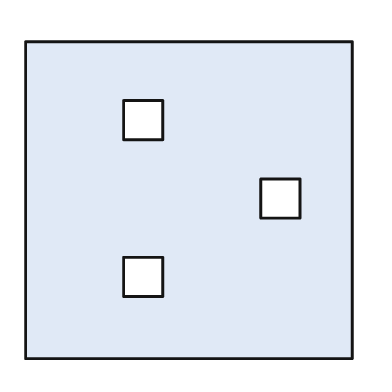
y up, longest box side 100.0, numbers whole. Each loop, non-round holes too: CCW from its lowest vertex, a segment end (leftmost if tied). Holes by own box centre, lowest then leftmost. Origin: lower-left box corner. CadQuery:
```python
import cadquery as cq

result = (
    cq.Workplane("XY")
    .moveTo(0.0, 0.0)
    .lineTo(100.0, 0.0)
    .lineTo(100.0, 97.0)
    .lineTo(0.0, 97.0)
    .close()
    .moveTo(30.0, 19.0)
    .lineTo(42.0, 19.0)
    .lineTo(42.0, 31.0)
    .lineTo(30.0, 31.0)
    .close()
    .moveTo(72.0, 43.0)
    .lineTo(84.0, 43.0)
    .lineTo(84.0, 55.0)
    .lineTo(72.0, 55.0)
    .close()
    .moveTo(30.0, 67.0)
    .lineTo(42.0, 67.0)
    .lineTo(42.0, 79.0)
    .lineTo(30.0, 79.0)
    .close()
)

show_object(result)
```